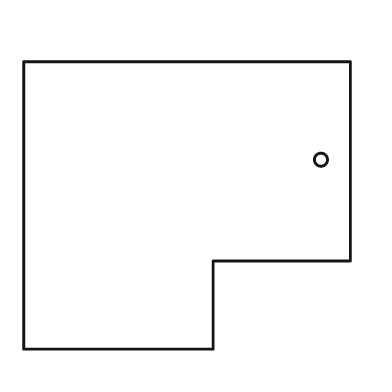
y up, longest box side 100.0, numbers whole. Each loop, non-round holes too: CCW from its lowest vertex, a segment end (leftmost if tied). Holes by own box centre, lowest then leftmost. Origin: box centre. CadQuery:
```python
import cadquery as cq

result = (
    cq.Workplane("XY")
    .moveTo(-50.0, -44.0)
    .lineTo(8.0, -44.0)
    .lineTo(8.0, -17.0)
    .lineTo(50.0, -17.0)
    .lineTo(50.0, 44.0)
    .lineTo(-50.0, 44.0)
    .close()
    .moveTo(41.0, 14.0)
    .circle(2.0)
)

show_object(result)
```